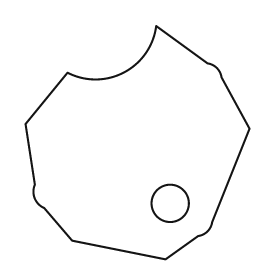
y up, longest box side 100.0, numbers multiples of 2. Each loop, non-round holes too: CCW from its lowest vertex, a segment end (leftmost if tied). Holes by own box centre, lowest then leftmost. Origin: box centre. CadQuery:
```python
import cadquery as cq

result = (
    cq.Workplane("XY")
    .moveTo(12.0, -50.0)
    .lineTo(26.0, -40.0)
    .threePointArc((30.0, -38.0), (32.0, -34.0))
    .lineTo(48.0, 6.0)
    .lineTo(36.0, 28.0)
    .threePointArc((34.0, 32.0), (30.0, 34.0))
    .lineTo(8.0, 50.0)
    .threePointArc((-6.0, 30.0), (-30.0, 30.0))
    .lineTo(-48.0, 8.0)
    .lineTo(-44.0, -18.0)
    .threePointArc((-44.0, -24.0), (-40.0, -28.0))
    .lineTo(-28.0, -42.0)
    .close()
    .moveTo(14.0, -26.0)
    .circle(8.0)
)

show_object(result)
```